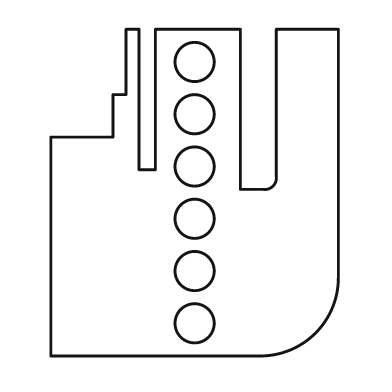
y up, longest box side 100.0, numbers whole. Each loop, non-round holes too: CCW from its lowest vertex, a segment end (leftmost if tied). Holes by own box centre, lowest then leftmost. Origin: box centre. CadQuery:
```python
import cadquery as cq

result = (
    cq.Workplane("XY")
    .moveTo(-44.0, -50.0)
    .lineTo(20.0, -50.0)
    .threePointArc((37.0, -43.0), (44.0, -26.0))
    .lineTo(44.0, 50.0)
    .lineTo(25.0, 50.0)
    .lineTo(25.0, 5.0)
    .threePointArc((24.0, 2.0), (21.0, 1.0))
    .lineTo(14.0, 1.0)
    .lineTo(14.0, 50.0)
    .lineTo(-12.0, 50.0)
    .lineTo(-12.0, 7.0)
    .lineTo(-17.0, 7.0)
    .lineTo(-17.0, 50.0)
    .lineTo(-21.0, 50.0)
    .lineTo(-21.0, 30.0)
    .lineTo(-25.0, 30.0)
    .lineTo(-25.0, 17.0)
    .lineTo(-44.0, 17.0)
    .close()
    .moveTo(0.0, -40.0)
    .circle(6.0)
    .moveTo(0.0, -24.0)
    .circle(6.0)
    .moveTo(0.0, -8.0)
    .circle(6.0)
    .moveTo(0.0, 8.0)
    .circle(6.0)
    .moveTo(0.0, 24.0)
    .circle(6.0)
    .moveTo(0.0, 40.0)
    .circle(6.0)
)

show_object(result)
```